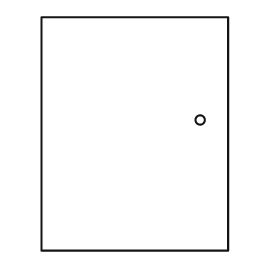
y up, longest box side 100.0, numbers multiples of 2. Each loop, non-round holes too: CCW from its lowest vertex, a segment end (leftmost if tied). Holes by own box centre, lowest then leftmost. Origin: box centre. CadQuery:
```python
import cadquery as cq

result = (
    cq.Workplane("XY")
    .moveTo(-40.0, -50.0)
    .lineTo(40.0, -50.0)
    .lineTo(40.0, 50.0)
    .lineTo(-40.0, 50.0)
    .close()
    .moveTo(28.0, 6.0)
    .circle(2.0)
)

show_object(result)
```